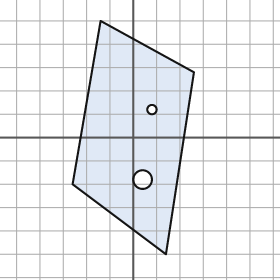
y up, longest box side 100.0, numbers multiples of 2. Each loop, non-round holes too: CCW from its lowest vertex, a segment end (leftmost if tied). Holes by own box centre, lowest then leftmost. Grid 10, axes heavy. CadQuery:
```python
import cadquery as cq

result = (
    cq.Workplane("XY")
    .moveTo(14.0, -50.0)
    .lineTo(26.0, 28.0)
    .lineTo(-14.0, 50.0)
    .lineTo(-26.0, -20.0)
    .close()
    .moveTo(4.0, -18.0)
    .circle(4.0)
    .moveTo(8.0, 12.0)
    .circle(2.0)
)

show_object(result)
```